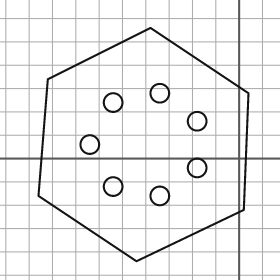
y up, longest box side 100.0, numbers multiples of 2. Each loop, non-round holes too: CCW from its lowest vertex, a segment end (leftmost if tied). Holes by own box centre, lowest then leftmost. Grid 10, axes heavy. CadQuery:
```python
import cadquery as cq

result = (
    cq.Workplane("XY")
    .moveTo(-44.0, -44.0)
    .lineTo(2.0, -22.0)
    .lineTo(4.0, 28.0)
    .lineTo(-38.0, 56.0)
    .lineTo(-82.0, 34.0)
    .lineTo(-86.0, -16.0)
    .close()
    .moveTo(-34.0, -16.0)
    .circle(4.0)
    .moveTo(-54.0, -12.0)
    .circle(4.0)
    .moveTo(-18.0, -4.0)
    .circle(4.0)
    .moveTo(-64.0, 6.0)
    .circle(4.0)
    .moveTo(-18.0, 16.0)
    .circle(4.0)
    .moveTo(-54.0, 24.0)
    .circle(4.0)
    .moveTo(-34.0, 28.0)
    .circle(4.0)
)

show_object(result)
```